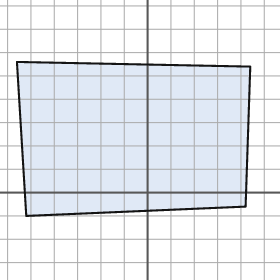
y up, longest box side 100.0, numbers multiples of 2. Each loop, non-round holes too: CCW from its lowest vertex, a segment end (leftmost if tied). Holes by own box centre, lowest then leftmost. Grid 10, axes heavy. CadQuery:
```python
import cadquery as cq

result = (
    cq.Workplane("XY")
    .moveTo(-52.0, -10.0)
    .lineTo(42.0, -6.0)
    .lineTo(44.0, 54.0)
    .lineTo(-56.0, 56.0)
    .close()
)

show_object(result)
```